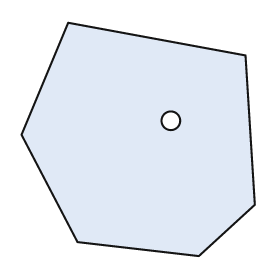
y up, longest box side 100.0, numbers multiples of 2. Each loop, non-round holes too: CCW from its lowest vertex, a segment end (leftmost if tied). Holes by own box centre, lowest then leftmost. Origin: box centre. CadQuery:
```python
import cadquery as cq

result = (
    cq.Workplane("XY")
    .moveTo(26.0, -50.0)
    .lineTo(50.0, -28.0)
    .lineTo(46.0, 36.0)
    .lineTo(-30.0, 50.0)
    .lineTo(-50.0, 2.0)
    .lineTo(-26.0, -44.0)
    .close()
    .moveTo(14.0, 8.0)
    .circle(4.0)
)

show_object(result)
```